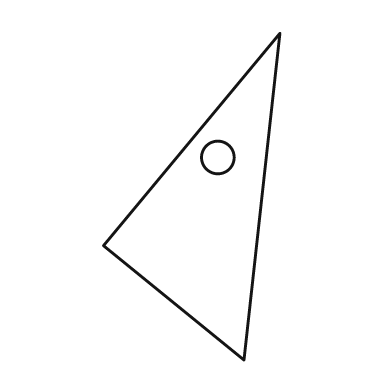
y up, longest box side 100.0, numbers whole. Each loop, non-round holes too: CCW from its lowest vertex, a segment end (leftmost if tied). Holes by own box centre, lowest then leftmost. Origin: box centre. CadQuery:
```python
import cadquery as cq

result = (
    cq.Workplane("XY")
    .moveTo(16.0, -50.0)
    .lineTo(27.0, 50.0)
    .lineTo(-27.0, -15.0)
    .close()
    .moveTo(8.0, 12.0)
    .circle(5.0)
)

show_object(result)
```